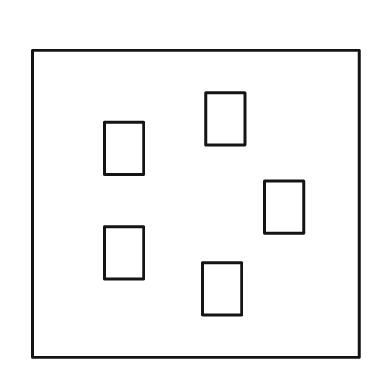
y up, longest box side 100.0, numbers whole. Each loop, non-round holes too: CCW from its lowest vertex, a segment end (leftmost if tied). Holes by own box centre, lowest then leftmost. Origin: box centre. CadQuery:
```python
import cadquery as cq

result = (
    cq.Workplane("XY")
    .moveTo(-50.0, -47.0)
    .lineTo(50.0, -47.0)
    .lineTo(50.0, 47.0)
    .lineTo(-50.0, 47.0)
    .close()
    .moveTo(2.0, -34.0)
    .lineTo(14.0, -34.0)
    .lineTo(14.0, -18.0)
    .lineTo(2.0, -18.0)
    .close()
    .moveTo(-28.0, -23.0)
    .lineTo(-16.0, -23.0)
    .lineTo(-16.0, -7.0)
    .lineTo(-28.0, -7.0)
    .close()
    .moveTo(21.0, -9.0)
    .lineTo(33.0, -9.0)
    .lineTo(33.0, 7.0)
    .lineTo(21.0, 7.0)
    .close()
    .moveTo(-28.0, 9.0)
    .lineTo(-16.0, 9.0)
    .lineTo(-16.0, 25.0)
    .lineTo(-28.0, 25.0)
    .close()
    .moveTo(3.0, 18.0)
    .lineTo(15.0, 18.0)
    .lineTo(15.0, 34.0)
    .lineTo(3.0, 34.0)
    .close()
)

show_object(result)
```